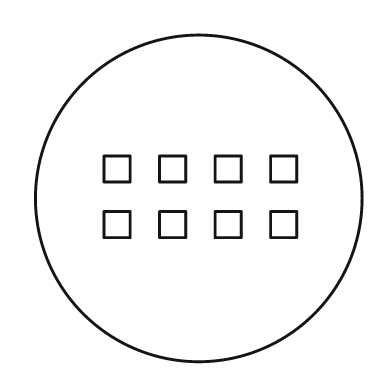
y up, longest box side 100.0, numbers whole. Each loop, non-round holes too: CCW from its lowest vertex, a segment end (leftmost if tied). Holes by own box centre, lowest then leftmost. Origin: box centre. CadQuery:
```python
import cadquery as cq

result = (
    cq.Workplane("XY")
    .moveTo(0.0, 0.0)
    .circle(50.0)
    .moveTo(-29.0, -12.0)
    .lineTo(-21.0, -12.0)
    .lineTo(-21.0, -4.0)
    .lineTo(-29.0, -4.0)
    .close()
    .moveTo(-12.0, -12.0)
    .lineTo(-4.0, -12.0)
    .lineTo(-4.0, -4.0)
    .lineTo(-12.0, -4.0)
    .close()
    .moveTo(5.0, -12.0)
    .lineTo(13.0, -12.0)
    .lineTo(13.0, -4.0)
    .lineTo(5.0, -4.0)
    .close()
    .moveTo(22.0, -12.0)
    .lineTo(30.0, -12.0)
    .lineTo(30.0, -4.0)
    .lineTo(22.0, -4.0)
    .close()
    .moveTo(-29.0, 5.0)
    .lineTo(-21.0, 5.0)
    .lineTo(-21.0, 13.0)
    .lineTo(-29.0, 13.0)
    .close()
    .moveTo(-12.0, 5.0)
    .lineTo(-4.0, 5.0)
    .lineTo(-4.0, 13.0)
    .lineTo(-12.0, 13.0)
    .close()
    .moveTo(5.0, 5.0)
    .lineTo(13.0, 5.0)
    .lineTo(13.0, 13.0)
    .lineTo(5.0, 13.0)
    .close()
    .moveTo(22.0, 5.0)
    .lineTo(30.0, 5.0)
    .lineTo(30.0, 13.0)
    .lineTo(22.0, 13.0)
    .close()
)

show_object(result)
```